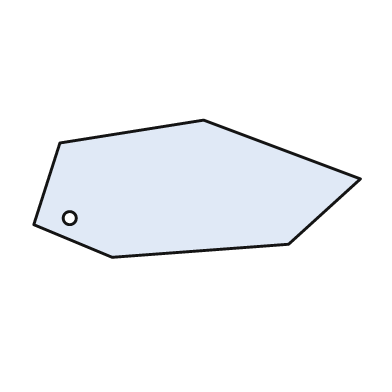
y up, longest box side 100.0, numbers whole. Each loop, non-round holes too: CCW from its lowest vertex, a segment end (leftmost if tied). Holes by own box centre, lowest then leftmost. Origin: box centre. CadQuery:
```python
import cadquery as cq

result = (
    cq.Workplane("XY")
    .moveTo(-26.0, -21.0)
    .lineTo(28.0, -17.0)
    .lineTo(50.0, 3.0)
    .lineTo(2.0, 21.0)
    .lineTo(-42.0, 14.0)
    .lineTo(-50.0, -11.0)
    .close()
    .moveTo(-39.0, -9.0)
    .circle(2.0)
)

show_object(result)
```